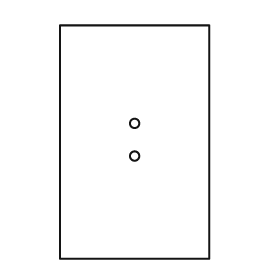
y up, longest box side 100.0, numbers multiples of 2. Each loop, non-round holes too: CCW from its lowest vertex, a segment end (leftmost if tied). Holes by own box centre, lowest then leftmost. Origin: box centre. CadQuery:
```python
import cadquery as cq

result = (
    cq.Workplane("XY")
    .moveTo(-32.0, -50.0)
    .lineTo(32.0, -50.0)
    .lineTo(32.0, 50.0)
    .lineTo(-32.0, 50.0)
    .close()
    .moveTo(0.0, -6.0)
    .circle(2.0)
    .moveTo(0.0, 8.0)
    .circle(2.0)
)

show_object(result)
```